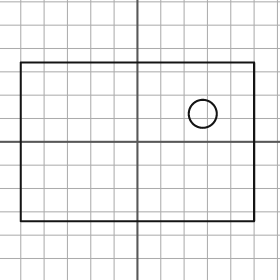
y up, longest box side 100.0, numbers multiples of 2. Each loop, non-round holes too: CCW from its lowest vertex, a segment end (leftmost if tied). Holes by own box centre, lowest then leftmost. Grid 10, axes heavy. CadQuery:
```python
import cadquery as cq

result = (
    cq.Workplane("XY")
    .moveTo(-50.0, -34.0)
    .lineTo(50.0, -34.0)
    .lineTo(50.0, 34.0)
    .lineTo(-50.0, 34.0)
    .close()
    .moveTo(28.0, 12.0)
    .circle(6.0)
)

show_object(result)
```